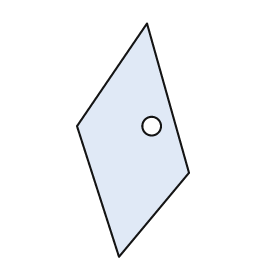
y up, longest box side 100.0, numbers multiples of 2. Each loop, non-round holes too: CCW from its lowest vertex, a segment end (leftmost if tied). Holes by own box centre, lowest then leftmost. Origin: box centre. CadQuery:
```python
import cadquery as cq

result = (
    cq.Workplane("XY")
    .moveTo(-6.0, -50.0)
    .lineTo(24.0, -14.0)
    .lineTo(6.0, 50.0)
    .lineTo(-24.0, 6.0)
    .close()
    .moveTo(8.0, 6.0)
    .circle(4.0)
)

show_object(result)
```